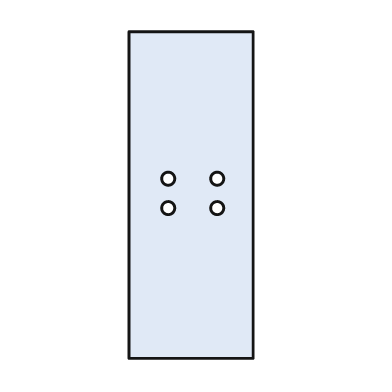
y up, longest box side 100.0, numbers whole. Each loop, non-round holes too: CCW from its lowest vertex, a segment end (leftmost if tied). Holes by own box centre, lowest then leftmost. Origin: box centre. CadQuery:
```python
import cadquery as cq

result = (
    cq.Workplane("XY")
    .moveTo(-19.0, -50.0)
    .lineTo(19.0, -50.0)
    .lineTo(19.0, 50.0)
    .lineTo(-19.0, 50.0)
    .close()
    .moveTo(-7.0, -4.0)
    .circle(2.0)
    .moveTo(8.0, -4.0)
    .circle(2.0)
    .moveTo(-7.0, 5.0)
    .circle(2.0)
    .moveTo(8.0, 5.0)
    .circle(2.0)
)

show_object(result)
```